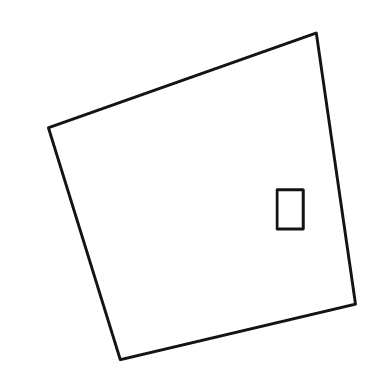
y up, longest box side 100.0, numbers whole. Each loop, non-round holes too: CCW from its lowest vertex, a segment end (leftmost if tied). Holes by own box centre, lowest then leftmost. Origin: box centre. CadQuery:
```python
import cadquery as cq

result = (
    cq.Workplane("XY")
    .moveTo(-25.0, -50.0)
    .lineTo(47.0, -33.0)
    .lineTo(35.0, 50.0)
    .lineTo(-47.0, 21.0)
    .close()
    .moveTo(23.0, -10.0)
    .lineTo(31.0, -10.0)
    .lineTo(31.0, 2.0)
    .lineTo(23.0, 2.0)
    .close()
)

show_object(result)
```